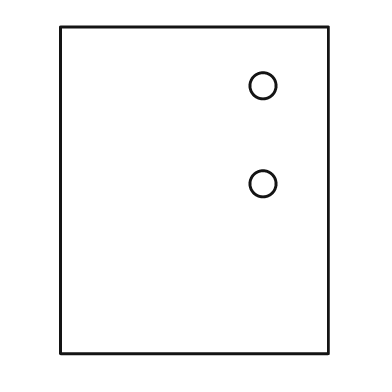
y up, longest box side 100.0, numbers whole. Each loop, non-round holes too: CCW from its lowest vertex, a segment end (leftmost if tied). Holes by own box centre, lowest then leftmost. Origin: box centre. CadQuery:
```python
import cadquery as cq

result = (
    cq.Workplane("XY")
    .moveTo(-41.0, -50.0)
    .lineTo(41.0, -50.0)
    .lineTo(41.0, 50.0)
    .lineTo(-41.0, 50.0)
    .close()
    .moveTo(21.0, 2.0)
    .circle(4.0)
    .moveTo(21.0, 32.0)
    .circle(4.0)
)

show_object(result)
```